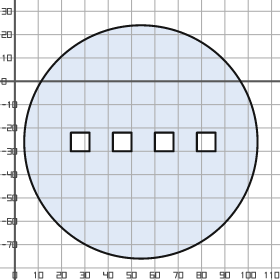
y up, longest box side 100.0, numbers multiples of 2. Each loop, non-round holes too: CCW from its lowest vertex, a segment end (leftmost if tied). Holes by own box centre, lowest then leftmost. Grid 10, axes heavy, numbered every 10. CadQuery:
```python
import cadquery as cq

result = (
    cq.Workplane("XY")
    .moveTo(54.0, -26.0)
    .circle(50.0)
    .moveTo(24.0, -30.0)
    .lineTo(32.0, -30.0)
    .lineTo(32.0, -22.0)
    .lineTo(24.0, -22.0)
    .close()
    .moveTo(42.0, -30.0)
    .lineTo(50.0, -30.0)
    .lineTo(50.0, -22.0)
    .lineTo(42.0, -22.0)
    .close()
    .moveTo(60.0, -30.0)
    .lineTo(68.0, -30.0)
    .lineTo(68.0, -22.0)
    .lineTo(60.0, -22.0)
    .close()
    .moveTo(78.0, -30.0)
    .lineTo(86.0, -30.0)
    .lineTo(86.0, -22.0)
    .lineTo(78.0, -22.0)
    .close()
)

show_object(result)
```